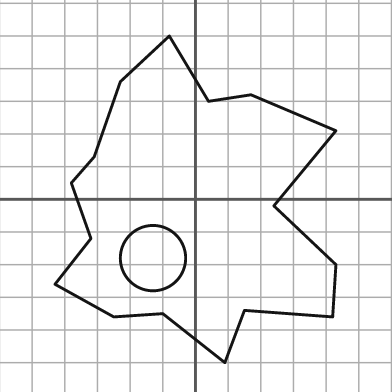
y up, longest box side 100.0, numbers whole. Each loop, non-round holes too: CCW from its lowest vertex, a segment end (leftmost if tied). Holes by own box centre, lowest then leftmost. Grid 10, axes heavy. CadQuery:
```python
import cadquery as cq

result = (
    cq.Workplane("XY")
    .moveTo(9.0, -50.0)
    .lineTo(15.0, -34.0)
    .lineTo(42.0, -36.0)
    .lineTo(43.0, -20.0)
    .lineTo(24.0, -2.0)
    .lineTo(43.0, 21.0)
    .lineTo(17.0, 32.0)
    .lineTo(4.0, 30.0)
    .lineTo(-8.0, 50.0)
    .lineTo(-23.0, 36.0)
    .lineTo(-31.0, 13.0)
    .lineTo(-38.0, 5.0)
    .lineTo(-32.0, -12.0)
    .lineTo(-43.0, -26.0)
    .lineTo(-25.0, -36.0)
    .lineTo(-10.0, -35.0)
    .close()
    .moveTo(-13.0, -18.0)
    .circle(10.0)
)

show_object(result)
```